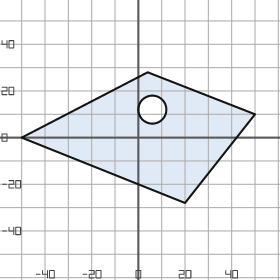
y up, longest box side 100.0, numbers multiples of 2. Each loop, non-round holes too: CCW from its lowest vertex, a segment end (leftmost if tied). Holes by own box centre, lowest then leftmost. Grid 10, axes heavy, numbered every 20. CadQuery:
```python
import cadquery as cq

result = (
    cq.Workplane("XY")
    .moveTo(20.0, -28.0)
    .lineTo(50.0, 10.0)
    .lineTo(4.0, 28.0)
    .lineTo(-50.0, 0.0)
    .close()
    .moveTo(6.0, 12.0)
    .circle(6.0)
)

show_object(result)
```